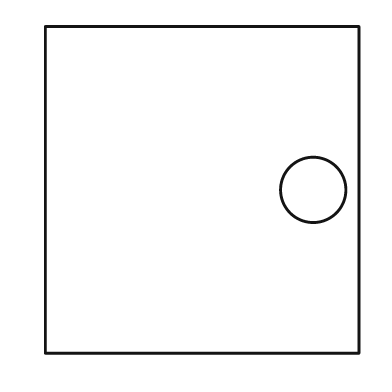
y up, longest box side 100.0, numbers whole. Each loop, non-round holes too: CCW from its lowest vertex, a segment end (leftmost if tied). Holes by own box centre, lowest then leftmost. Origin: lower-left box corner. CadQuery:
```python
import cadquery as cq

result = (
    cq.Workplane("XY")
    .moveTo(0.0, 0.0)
    .lineTo(96.0, 0.0)
    .lineTo(96.0, 100.0)
    .lineTo(0.0, 100.0)
    .close()
    .moveTo(82.0, 50.0)
    .circle(10.0)
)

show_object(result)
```